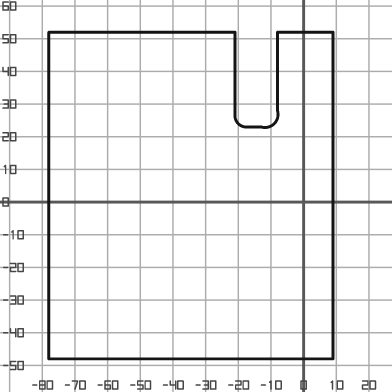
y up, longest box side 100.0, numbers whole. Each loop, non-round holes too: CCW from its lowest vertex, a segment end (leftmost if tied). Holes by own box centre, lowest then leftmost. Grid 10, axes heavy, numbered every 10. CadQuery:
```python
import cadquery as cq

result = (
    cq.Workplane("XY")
    .moveTo(-78.0, -48.0)
    .lineTo(9.0, -48.0)
    .lineTo(9.0, 52.0)
    .lineTo(-8.0, 52.0)
    .lineTo(-8.0, 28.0)
    .threePointArc((-9.0, 24.0), (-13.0, 23.0))
    .lineTo(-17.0, 23.0)
    .threePointArc((-20.0, 24.0), (-21.0, 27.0))
    .lineTo(-21.0, 52.0)
    .lineTo(-78.0, 52.0)
    .close()
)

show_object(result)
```